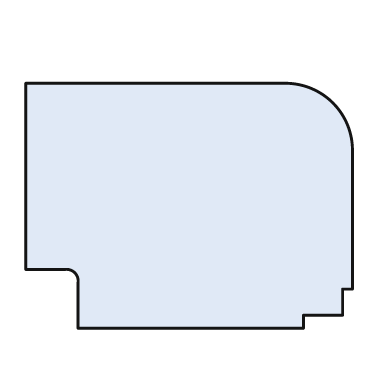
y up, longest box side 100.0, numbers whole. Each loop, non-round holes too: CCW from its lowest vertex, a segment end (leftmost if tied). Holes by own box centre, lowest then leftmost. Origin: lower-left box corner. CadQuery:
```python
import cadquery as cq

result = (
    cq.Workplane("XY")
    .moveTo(16.0, 0.0)
    .lineTo(85.0, 0.0)
    .lineTo(85.0, 4.0)
    .lineTo(97.0, 4.0)
    .lineTo(97.0, 12.0)
    .lineTo(100.0, 12.0)
    .lineTo(100.0, 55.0)
    .threePointArc((94.0, 69.0), (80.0, 75.0))
    .lineTo(0.0, 75.0)
    .lineTo(0.0, 18.0)
    .lineTo(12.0, 18.0)
    .threePointArc((15.0, 17.0), (16.0, 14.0))
    .close()
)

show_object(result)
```